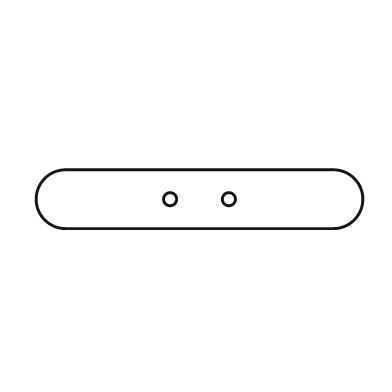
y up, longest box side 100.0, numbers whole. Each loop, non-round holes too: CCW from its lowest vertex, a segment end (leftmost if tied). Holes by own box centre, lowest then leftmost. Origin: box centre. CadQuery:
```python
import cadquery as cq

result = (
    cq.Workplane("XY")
    .moveTo(-41.0, -9.0)
    .lineTo(41.0, -9.0)
    .threePointArc((50.0, 0.0), (41.0, 9.0))
    .lineTo(-41.0, 9.0)
    .threePointArc((-50.0, 0.0), (-41.0, -9.0))
    .close()
    .moveTo(-9.0, 0.0)
    .circle(2.0)
    .moveTo(9.0, 0.0)
    .circle(2.0)
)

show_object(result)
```